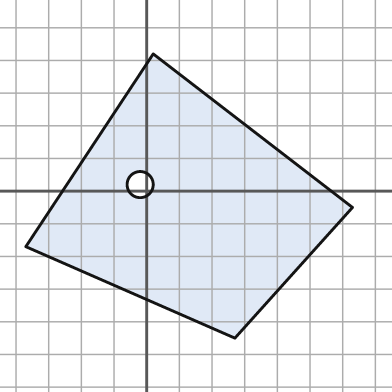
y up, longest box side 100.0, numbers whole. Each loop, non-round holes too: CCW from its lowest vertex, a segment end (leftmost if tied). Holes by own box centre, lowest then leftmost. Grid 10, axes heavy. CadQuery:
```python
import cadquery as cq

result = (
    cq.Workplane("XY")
    .moveTo(27.0, -45.0)
    .lineTo(63.0, -5.0)
    .lineTo(2.0, 42.0)
    .lineTo(-37.0, -17.0)
    .close()
    .moveTo(-2.0, 2.0)
    .circle(4.0)
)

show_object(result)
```